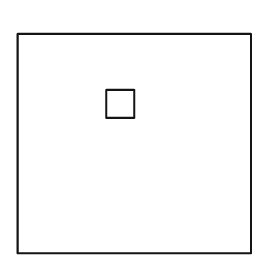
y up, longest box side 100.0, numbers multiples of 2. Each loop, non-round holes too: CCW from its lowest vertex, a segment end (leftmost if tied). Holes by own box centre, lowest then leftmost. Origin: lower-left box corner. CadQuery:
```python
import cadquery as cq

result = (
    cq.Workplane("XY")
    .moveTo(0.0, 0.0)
    .lineTo(100.0, 0.0)
    .lineTo(100.0, 94.0)
    .lineTo(0.0, 94.0)
    .close()
    .moveTo(38.0, 58.0)
    .lineTo(50.0, 58.0)
    .lineTo(50.0, 70.0)
    .lineTo(38.0, 70.0)
    .close()
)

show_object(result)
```